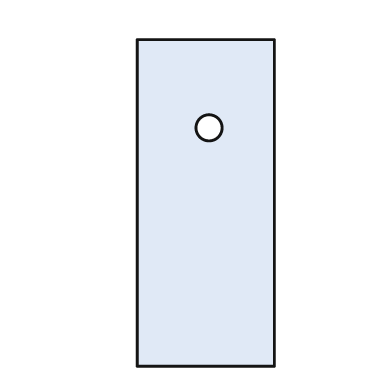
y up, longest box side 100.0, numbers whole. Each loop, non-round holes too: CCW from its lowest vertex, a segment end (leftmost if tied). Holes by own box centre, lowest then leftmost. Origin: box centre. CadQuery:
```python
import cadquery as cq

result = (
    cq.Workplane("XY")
    .moveTo(-21.0, -50.0)
    .lineTo(21.0, -50.0)
    .lineTo(21.0, 50.0)
    .lineTo(-21.0, 50.0)
    .close()
    .moveTo(1.0, 23.0)
    .circle(4.0)
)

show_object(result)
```